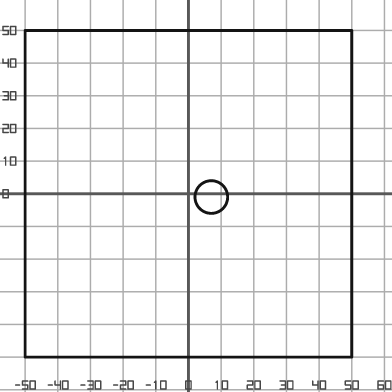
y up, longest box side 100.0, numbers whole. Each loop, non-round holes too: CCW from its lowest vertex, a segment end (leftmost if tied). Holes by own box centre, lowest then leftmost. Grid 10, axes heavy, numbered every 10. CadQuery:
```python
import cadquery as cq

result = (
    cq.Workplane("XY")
    .moveTo(-50.0, -50.0)
    .lineTo(50.0, -50.0)
    .lineTo(50.0, 50.0)
    .lineTo(-50.0, 50.0)
    .close()
    .moveTo(7.0, -1.0)
    .circle(5.0)
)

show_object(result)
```